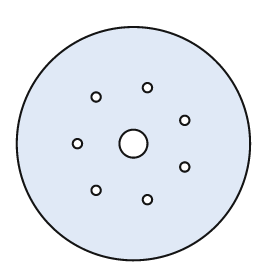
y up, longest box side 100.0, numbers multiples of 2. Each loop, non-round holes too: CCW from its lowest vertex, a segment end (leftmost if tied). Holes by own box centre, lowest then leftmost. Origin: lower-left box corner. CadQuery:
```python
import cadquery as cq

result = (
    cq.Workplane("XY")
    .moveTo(50.0, 50.0)
    .circle(50.0)
    .moveTo(56.0, 26.0)
    .circle(2.0)
    .moveTo(34.0, 30.0)
    .circle(2.0)
    .moveTo(72.0, 40.0)
    .circle(2.0)
    .moveTo(26.0, 50.0)
    .circle(2.0)
    .moveTo(50.0, 50.0)
    .circle(6.0)
    .moveTo(72.0, 60.0)
    .circle(2.0)
    .moveTo(34.0, 70.0)
    .circle(2.0)
    .moveTo(56.0, 74.0)
    .circle(2.0)
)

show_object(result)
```